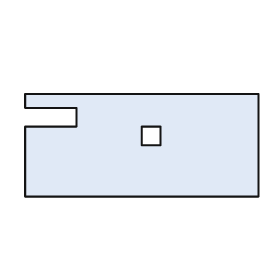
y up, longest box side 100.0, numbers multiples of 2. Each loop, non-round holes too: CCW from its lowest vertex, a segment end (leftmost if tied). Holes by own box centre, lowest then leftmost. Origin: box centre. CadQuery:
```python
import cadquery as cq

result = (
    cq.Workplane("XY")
    .moveTo(-50.0, -22.0)
    .lineTo(50.0, -22.0)
    .lineTo(50.0, 22.0)
    .lineTo(-50.0, 22.0)
    .lineTo(-50.0, 16.0)
    .lineTo(-28.0, 16.0)
    .lineTo(-28.0, 8.0)
    .lineTo(-50.0, 8.0)
    .close()
    .moveTo(0.0, 0.0)
    .lineTo(8.0, 0.0)
    .lineTo(8.0, 8.0)
    .lineTo(0.0, 8.0)
    .close()
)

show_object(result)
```